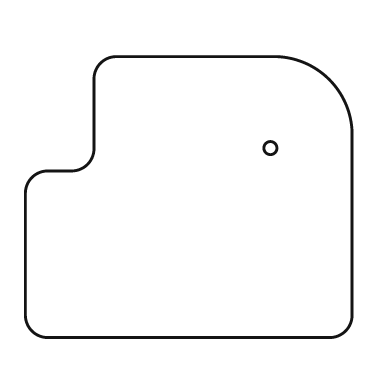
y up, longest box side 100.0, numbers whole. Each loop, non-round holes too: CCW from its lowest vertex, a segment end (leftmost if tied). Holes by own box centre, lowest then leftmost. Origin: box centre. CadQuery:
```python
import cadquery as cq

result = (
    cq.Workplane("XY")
    .moveTo(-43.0, -43.0)
    .lineTo(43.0, -43.0)
    .threePointArc((48.0, -41.0), (50.0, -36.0))
    .lineTo(50.0, 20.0)
    .threePointArc((43.0, 36.0), (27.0, 43.0))
    .lineTo(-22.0, 43.0)
    .threePointArc((-27.0, 41.0), (-29.0, 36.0))
    .lineTo(-29.0, 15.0)
    .threePointArc((-31.0, 10.0), (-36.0, 8.0))
    .lineTo(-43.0, 8.0)
    .threePointArc((-48.0, 6.0), (-50.0, 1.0))
    .lineTo(-50.0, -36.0)
    .threePointArc((-48.0, -41.0), (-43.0, -43.0))
    .close()
    .moveTo(25.0, 15.0)
    .circle(2.0)
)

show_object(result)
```